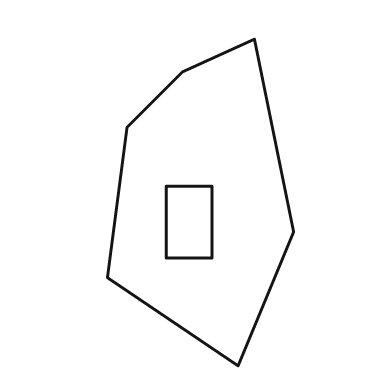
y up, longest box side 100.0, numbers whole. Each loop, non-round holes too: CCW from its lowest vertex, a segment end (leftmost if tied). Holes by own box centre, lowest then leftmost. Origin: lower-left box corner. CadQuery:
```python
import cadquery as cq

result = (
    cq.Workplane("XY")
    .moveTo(40.0, 0.0)
    .lineTo(57.0, 41.0)
    .lineTo(45.0, 100.0)
    .lineTo(23.0, 90.0)
    .lineTo(6.0, 73.0)
    .lineTo(0.0, 27.0)
    .close()
    .moveTo(18.0, 33.0)
    .lineTo(32.0, 33.0)
    .lineTo(32.0, 55.0)
    .lineTo(18.0, 55.0)
    .close()
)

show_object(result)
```